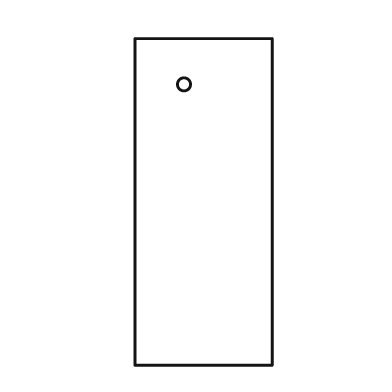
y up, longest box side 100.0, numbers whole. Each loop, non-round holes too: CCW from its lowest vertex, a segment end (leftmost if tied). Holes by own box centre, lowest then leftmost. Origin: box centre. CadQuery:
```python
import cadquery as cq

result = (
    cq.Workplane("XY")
    .moveTo(-21.0, -50.0)
    .lineTo(21.0, -50.0)
    .lineTo(21.0, 50.0)
    .lineTo(-21.0, 50.0)
    .close()
    .moveTo(-6.0, 36.0)
    .circle(2.0)
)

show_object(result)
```